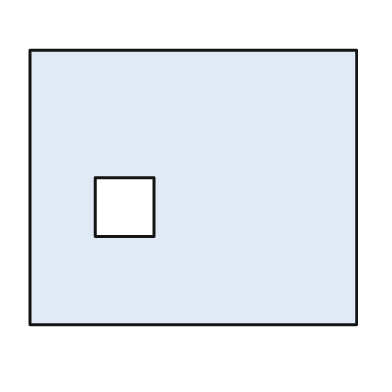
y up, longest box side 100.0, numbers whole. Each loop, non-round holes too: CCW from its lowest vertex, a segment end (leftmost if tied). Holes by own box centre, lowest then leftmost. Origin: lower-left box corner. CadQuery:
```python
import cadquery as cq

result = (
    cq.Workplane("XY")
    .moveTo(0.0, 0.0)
    .lineTo(100.0, 0.0)
    .lineTo(100.0, 84.0)
    .lineTo(0.0, 84.0)
    .close()
    .moveTo(20.0, 27.0)
    .lineTo(38.0, 27.0)
    .lineTo(38.0, 45.0)
    .lineTo(20.0, 45.0)
    .close()
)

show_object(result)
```